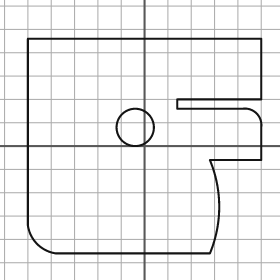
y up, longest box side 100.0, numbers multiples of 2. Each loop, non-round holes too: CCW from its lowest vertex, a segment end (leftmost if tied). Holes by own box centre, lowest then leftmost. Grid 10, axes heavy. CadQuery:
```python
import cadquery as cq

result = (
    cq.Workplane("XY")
    .moveTo(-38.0, -46.0)
    .lineTo(28.0, -46.0)
    .threePointArc((32.0, -26.0), (28.0, -6.0))
    .lineTo(50.0, -6.0)
    .lineTo(50.0, 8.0)
    .threePointArc((48.0, 14.0), (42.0, 16.0))
    .lineTo(14.0, 16.0)
    .lineTo(14.0, 20.0)
    .lineTo(50.0, 20.0)
    .lineTo(50.0, 46.0)
    .lineTo(-50.0, 46.0)
    .lineTo(-50.0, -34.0)
    .threePointArc((-46.0, -42.0), (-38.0, -46.0))
    .close()
    .moveTo(-4.0, 8.0)
    .circle(8.0)
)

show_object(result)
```